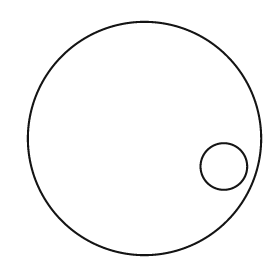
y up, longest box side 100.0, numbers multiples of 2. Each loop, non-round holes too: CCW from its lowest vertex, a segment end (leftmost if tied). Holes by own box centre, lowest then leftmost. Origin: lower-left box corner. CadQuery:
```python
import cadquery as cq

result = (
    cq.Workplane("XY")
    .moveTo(50.0, 50.0)
    .circle(50.0)
    .moveTo(84.0, 38.0)
    .circle(10.0)
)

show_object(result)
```